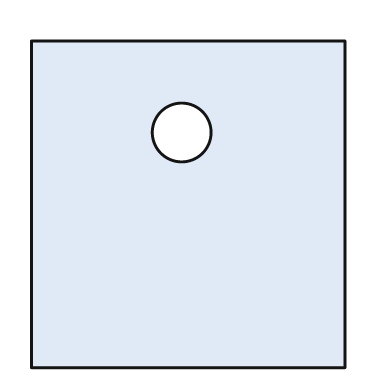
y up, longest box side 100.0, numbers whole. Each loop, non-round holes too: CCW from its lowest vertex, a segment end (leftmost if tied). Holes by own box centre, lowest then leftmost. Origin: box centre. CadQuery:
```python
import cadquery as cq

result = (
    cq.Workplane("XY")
    .moveTo(-48.0, -50.0)
    .lineTo(48.0, -50.0)
    .lineTo(48.0, 50.0)
    .lineTo(-48.0, 50.0)
    .close()
    .moveTo(-2.0, 22.0)
    .circle(9.0)
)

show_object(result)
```